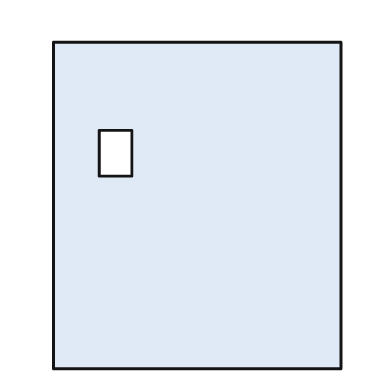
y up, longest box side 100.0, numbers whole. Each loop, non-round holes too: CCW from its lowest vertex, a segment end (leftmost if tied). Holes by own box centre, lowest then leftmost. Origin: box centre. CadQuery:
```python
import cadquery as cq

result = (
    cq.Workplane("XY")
    .moveTo(-44.0, -50.0)
    .lineTo(44.0, -50.0)
    .lineTo(44.0, 50.0)
    .lineTo(-44.0, 50.0)
    .close()
    .moveTo(-30.0, 9.0)
    .lineTo(-20.0, 9.0)
    .lineTo(-20.0, 23.0)
    .lineTo(-30.0, 23.0)
    .close()
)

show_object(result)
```